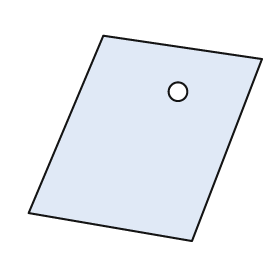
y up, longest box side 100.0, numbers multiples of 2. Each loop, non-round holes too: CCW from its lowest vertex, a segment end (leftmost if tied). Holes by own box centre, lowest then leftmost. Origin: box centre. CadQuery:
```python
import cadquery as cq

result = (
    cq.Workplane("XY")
    .moveTo(20.0, -44.0)
    .lineTo(50.0, 34.0)
    .lineTo(-18.0, 44.0)
    .lineTo(-50.0, -32.0)
    .close()
    .moveTo(14.0, 20.0)
    .circle(4.0)
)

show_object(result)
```